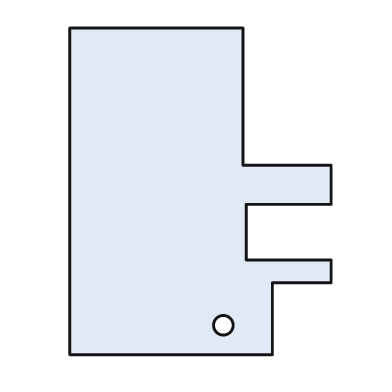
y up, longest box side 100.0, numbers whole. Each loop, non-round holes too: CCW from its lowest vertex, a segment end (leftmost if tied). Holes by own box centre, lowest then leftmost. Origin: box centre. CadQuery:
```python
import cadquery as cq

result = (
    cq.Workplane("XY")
    .moveTo(-40.0, -50.0)
    .lineTo(22.0, -50.0)
    .lineTo(22.0, -28.0)
    .lineTo(40.0, -28.0)
    .lineTo(40.0, -21.0)
    .lineTo(14.0, -21.0)
    .lineTo(14.0, -4.0)
    .lineTo(40.0, -4.0)
    .lineTo(40.0, 8.0)
    .lineTo(13.0, 8.0)
    .lineTo(13.0, 50.0)
    .lineTo(-40.0, 50.0)
    .close()
    .moveTo(7.0, -41.0)
    .circle(3.0)
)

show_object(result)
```